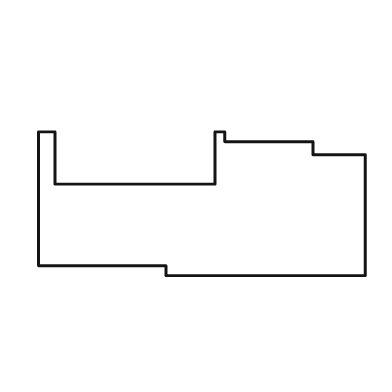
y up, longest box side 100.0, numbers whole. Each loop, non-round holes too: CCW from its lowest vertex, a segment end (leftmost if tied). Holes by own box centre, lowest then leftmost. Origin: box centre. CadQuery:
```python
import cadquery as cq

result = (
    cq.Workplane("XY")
    .moveTo(-11.0, -22.0)
    .lineTo(50.0, -22.0)
    .lineTo(50.0, 15.0)
    .lineTo(34.0, 15.0)
    .lineTo(34.0, 19.0)
    .lineTo(7.0, 19.0)
    .lineTo(7.0, 22.0)
    .lineTo(4.0, 22.0)
    .lineTo(4.0, 6.0)
    .lineTo(-45.0, 6.0)
    .lineTo(-45.0, 22.0)
    .lineTo(-50.0, 22.0)
    .lineTo(-50.0, -19.0)
    .lineTo(-11.0, -19.0)
    .close()
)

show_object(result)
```